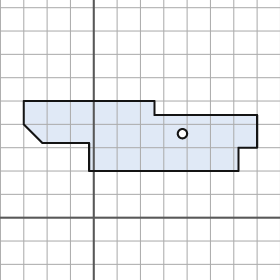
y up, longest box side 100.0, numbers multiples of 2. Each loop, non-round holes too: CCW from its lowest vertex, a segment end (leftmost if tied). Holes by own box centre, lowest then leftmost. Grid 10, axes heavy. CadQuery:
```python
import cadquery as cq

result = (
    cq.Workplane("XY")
    .moveTo(-2.0, 20.0)
    .lineTo(62.0, 20.0)
    .lineTo(62.0, 30.0)
    .lineTo(70.0, 30.0)
    .lineTo(70.0, 44.0)
    .lineTo(26.0, 44.0)
    .lineTo(26.0, 50.0)
    .lineTo(-30.0, 50.0)
    .lineTo(-30.0, 40.0)
    .lineTo(-22.0, 32.0)
    .lineTo(-2.0, 32.0)
    .close()
    .moveTo(38.0, 36.0)
    .circle(2.0)
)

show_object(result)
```